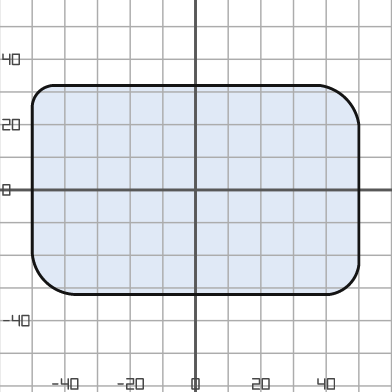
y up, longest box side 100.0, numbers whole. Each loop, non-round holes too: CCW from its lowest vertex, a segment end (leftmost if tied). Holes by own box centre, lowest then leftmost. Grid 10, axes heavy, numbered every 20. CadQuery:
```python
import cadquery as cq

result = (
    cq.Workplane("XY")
    .moveTo(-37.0, -32.0)
    .lineTo(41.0, -32.0)
    .threePointArc((47.0, -29.0), (50.0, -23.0))
    .lineTo(50.0, 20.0)
    .threePointArc((46.0, 28.0), (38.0, 32.0))
    .lineTo(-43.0, 32.0)
    .threePointArc((-48.0, 30.0), (-50.0, 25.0))
    .lineTo(-50.0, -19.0)
    .threePointArc((-46.0, -28.0), (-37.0, -32.0))
    .close()
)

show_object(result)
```